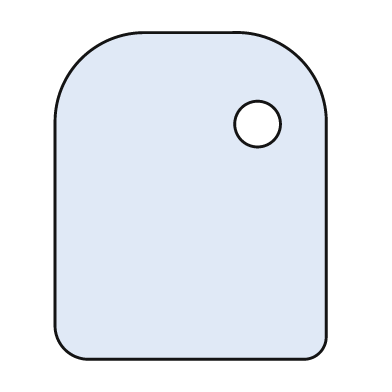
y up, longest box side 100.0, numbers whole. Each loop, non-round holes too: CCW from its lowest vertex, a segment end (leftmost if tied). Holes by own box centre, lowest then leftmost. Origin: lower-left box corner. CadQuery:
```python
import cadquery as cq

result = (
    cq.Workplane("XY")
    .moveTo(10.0, 0.0)
    .lineTo(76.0, 0.0)
    .threePointArc((81.0, 2.0), (83.0, 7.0))
    .lineTo(83.0, 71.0)
    .threePointArc((75.0, 92.0), (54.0, 100.0))
    .lineTo(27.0, 100.0)
    .threePointArc((8.0, 92.0), (0.0, 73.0))
    .lineTo(0.0, 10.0)
    .threePointArc((3.0, 3.0), (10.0, 0.0))
    .close()
    .moveTo(62.0, 72.0)
    .circle(7.0)
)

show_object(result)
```